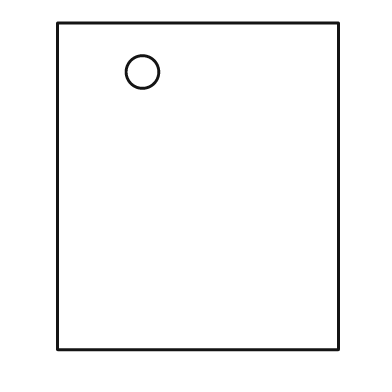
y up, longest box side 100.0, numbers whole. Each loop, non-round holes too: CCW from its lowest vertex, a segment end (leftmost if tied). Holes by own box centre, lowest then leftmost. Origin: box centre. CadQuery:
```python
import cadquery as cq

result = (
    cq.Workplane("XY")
    .moveTo(-43.0, -50.0)
    .lineTo(43.0, -50.0)
    .lineTo(43.0, 50.0)
    .lineTo(-43.0, 50.0)
    .close()
    .moveTo(-17.0, 35.0)
    .circle(5.0)
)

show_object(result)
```